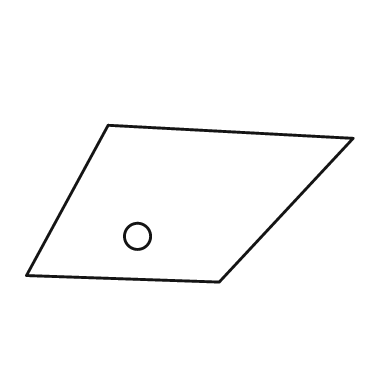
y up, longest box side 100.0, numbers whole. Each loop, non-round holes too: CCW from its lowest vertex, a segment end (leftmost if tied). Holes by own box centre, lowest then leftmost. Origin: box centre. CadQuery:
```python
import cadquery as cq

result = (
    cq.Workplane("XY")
    .moveTo(9.0, -24.0)
    .lineTo(50.0, 20.0)
    .lineTo(-25.0, 24.0)
    .lineTo(-50.0, -22.0)
    .close()
    .moveTo(-16.0, -10.0)
    .circle(4.0)
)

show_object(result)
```